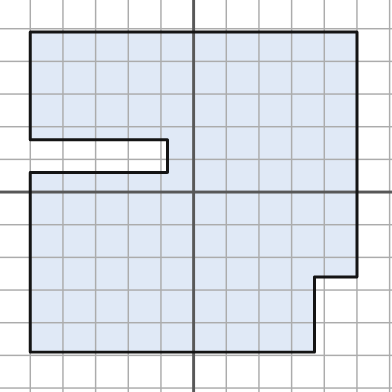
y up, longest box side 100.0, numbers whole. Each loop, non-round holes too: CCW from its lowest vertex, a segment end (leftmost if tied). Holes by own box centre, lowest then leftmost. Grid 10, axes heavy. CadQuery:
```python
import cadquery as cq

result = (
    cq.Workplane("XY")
    .moveTo(-50.0, -49.0)
    .lineTo(37.0, -49.0)
    .lineTo(37.0, -26.0)
    .lineTo(50.0, -26.0)
    .lineTo(50.0, 49.0)
    .lineTo(-50.0, 49.0)
    .lineTo(-50.0, 16.0)
    .lineTo(-8.0, 16.0)
    .lineTo(-8.0, 6.0)
    .lineTo(-50.0, 6.0)
    .close()
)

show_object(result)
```